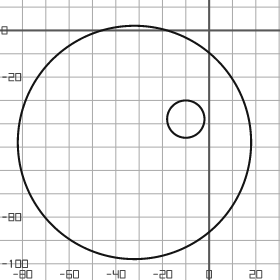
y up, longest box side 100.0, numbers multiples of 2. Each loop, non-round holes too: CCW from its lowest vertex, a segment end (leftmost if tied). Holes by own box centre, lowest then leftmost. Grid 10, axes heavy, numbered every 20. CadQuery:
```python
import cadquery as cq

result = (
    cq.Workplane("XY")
    .moveTo(-32.0, -48.0)
    .circle(50.0)
    .moveTo(-10.0, -38.0)
    .circle(8.0)
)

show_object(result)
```